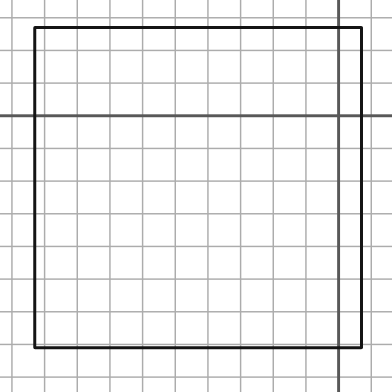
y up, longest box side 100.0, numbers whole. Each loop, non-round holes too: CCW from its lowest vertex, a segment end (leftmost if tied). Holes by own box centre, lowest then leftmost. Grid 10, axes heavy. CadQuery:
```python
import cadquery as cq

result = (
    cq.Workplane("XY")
    .moveTo(-93.0, -71.0)
    .lineTo(7.0, -71.0)
    .lineTo(7.0, 27.0)
    .lineTo(-93.0, 27.0)
    .close()
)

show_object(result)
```